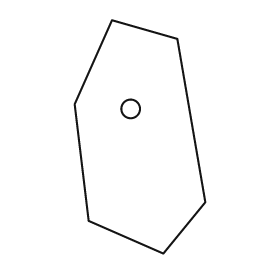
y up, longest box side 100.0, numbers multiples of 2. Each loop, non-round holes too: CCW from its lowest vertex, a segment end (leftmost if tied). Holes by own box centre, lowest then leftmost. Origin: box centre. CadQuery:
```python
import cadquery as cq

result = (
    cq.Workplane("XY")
    .moveTo(10.0, -50.0)
    .lineTo(28.0, -28.0)
    .lineTo(16.0, 42.0)
    .lineTo(-12.0, 50.0)
    .lineTo(-28.0, 14.0)
    .lineTo(-22.0, -36.0)
    .close()
    .moveTo(-4.0, 12.0)
    .circle(4.0)
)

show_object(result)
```